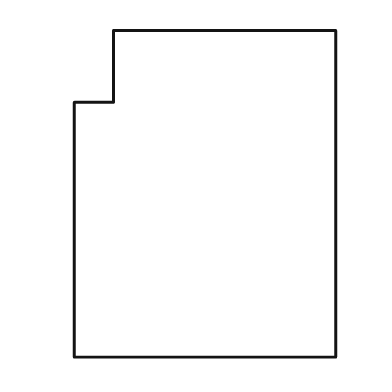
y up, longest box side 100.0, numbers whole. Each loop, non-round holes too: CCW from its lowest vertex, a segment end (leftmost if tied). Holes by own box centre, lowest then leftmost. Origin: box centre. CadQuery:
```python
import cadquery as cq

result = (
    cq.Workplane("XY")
    .moveTo(-40.0, -50.0)
    .lineTo(40.0, -50.0)
    .lineTo(40.0, 50.0)
    .lineTo(-28.0, 50.0)
    .lineTo(-28.0, 28.0)
    .lineTo(-40.0, 28.0)
    .close()
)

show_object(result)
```